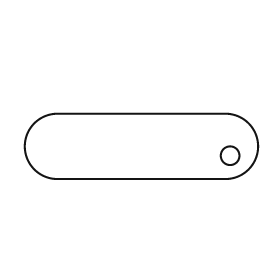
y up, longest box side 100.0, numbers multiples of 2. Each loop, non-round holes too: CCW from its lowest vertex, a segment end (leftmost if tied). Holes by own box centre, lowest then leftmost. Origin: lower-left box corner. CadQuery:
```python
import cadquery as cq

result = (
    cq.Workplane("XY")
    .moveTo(14.0, 0.0)
    .lineTo(86.0, 0.0)
    .threePointArc((100.0, 14.0), (86.0, 28.0))
    .lineTo(14.0, 28.0)
    .threePointArc((0.0, 14.0), (14.0, 0.0))
    .close()
    .moveTo(88.0, 10.0)
    .circle(4.0)
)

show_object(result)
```